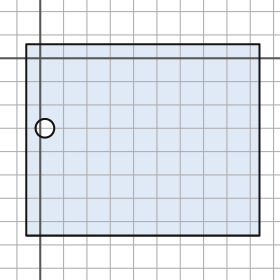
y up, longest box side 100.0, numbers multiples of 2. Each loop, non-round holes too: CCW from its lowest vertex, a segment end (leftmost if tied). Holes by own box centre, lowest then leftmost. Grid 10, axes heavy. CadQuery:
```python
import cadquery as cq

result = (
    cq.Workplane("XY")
    .moveTo(-6.0, -76.0)
    .lineTo(94.0, -76.0)
    .lineTo(94.0, 6.0)
    .lineTo(-6.0, 6.0)
    .close()
    .moveTo(2.0, -30.0)
    .circle(4.0)
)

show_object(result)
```